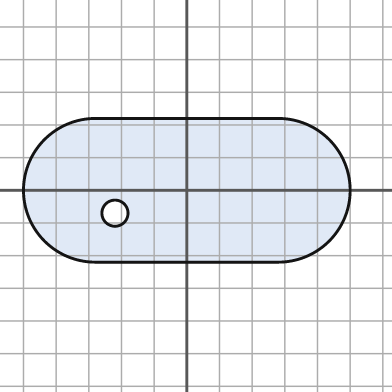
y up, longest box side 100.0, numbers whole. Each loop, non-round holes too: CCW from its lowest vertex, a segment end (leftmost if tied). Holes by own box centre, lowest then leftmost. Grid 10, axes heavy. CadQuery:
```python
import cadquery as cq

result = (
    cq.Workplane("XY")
    .moveTo(-28.0, -22.0)
    .lineTo(28.0, -22.0)
    .threePointArc((50.0, 0.0), (28.0, 22.0))
    .lineTo(-28.0, 22.0)
    .threePointArc((-50.0, 0.0), (-28.0, -22.0))
    .close()
    .moveTo(-22.0, -7.0)
    .circle(4.0)
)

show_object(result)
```